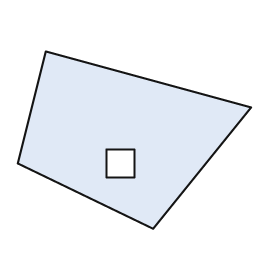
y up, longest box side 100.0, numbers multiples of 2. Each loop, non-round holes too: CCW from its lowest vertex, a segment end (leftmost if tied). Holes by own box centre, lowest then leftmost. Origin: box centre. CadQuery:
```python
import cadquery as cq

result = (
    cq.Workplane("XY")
    .moveTo(8.0, -38.0)
    .lineTo(50.0, 14.0)
    .lineTo(-38.0, 38.0)
    .lineTo(-50.0, -10.0)
    .close()
    .moveTo(-12.0, -16.0)
    .lineTo(0.0, -16.0)
    .lineTo(0.0, -4.0)
    .lineTo(-12.0, -4.0)
    .close()
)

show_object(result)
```